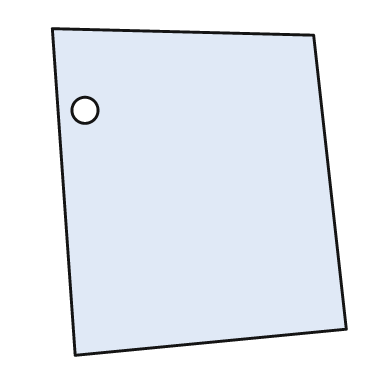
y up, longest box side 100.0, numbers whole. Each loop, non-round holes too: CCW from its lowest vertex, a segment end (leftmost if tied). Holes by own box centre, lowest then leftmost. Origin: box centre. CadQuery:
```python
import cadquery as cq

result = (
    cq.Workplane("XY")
    .moveTo(-38.0, -50.0)
    .lineTo(45.0, -42.0)
    .lineTo(35.0, 48.0)
    .lineTo(-45.0, 50.0)
    .close()
    .moveTo(-35.0, 25.0)
    .circle(4.0)
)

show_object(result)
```